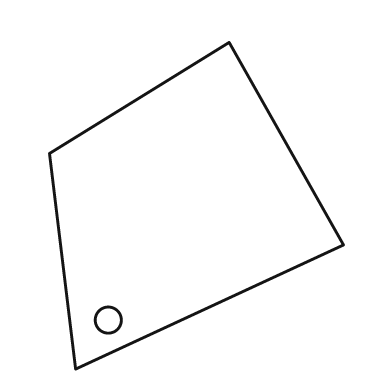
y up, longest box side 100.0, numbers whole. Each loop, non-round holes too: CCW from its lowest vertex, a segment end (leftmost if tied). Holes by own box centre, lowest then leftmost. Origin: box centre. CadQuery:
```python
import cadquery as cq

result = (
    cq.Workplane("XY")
    .moveTo(-37.0, -50.0)
    .lineTo(45.0, -12.0)
    .lineTo(10.0, 50.0)
    .lineTo(-45.0, 16.0)
    .close()
    .moveTo(-27.0, -35.0)
    .circle(4.0)
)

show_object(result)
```